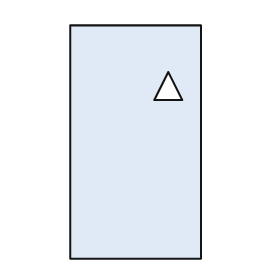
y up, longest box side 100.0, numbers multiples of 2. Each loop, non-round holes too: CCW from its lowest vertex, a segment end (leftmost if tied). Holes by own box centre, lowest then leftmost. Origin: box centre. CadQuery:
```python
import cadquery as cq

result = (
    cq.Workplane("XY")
    .moveTo(-28.0, -50.0)
    .lineTo(28.0, -50.0)
    .lineTo(28.0, 50.0)
    .lineTo(-28.0, 50.0)
    .close()
    .moveTo(8.0, 18.0)
    .lineTo(20.0, 18.0)
    .lineTo(14.0, 30.0)
    .close()
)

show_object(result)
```